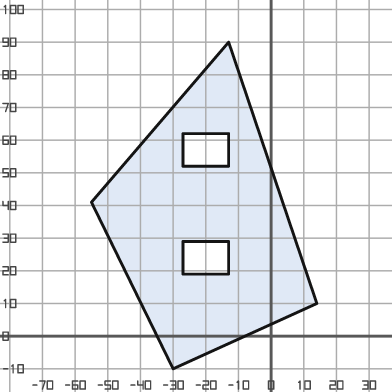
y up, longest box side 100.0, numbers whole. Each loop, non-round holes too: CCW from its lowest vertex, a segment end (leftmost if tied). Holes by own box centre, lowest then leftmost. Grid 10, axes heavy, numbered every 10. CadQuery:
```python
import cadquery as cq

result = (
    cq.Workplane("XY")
    .moveTo(-30.0, -10.0)
    .lineTo(14.0, 10.0)
    .lineTo(-13.0, 90.0)
    .lineTo(-55.0, 41.0)
    .close()
    .moveTo(-27.0, 19.0)
    .lineTo(-13.0, 19.0)
    .lineTo(-13.0, 29.0)
    .lineTo(-27.0, 29.0)
    .close()
    .moveTo(-27.0, 52.0)
    .lineTo(-13.0, 52.0)
    .lineTo(-13.0, 62.0)
    .lineTo(-27.0, 62.0)
    .close()
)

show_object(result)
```